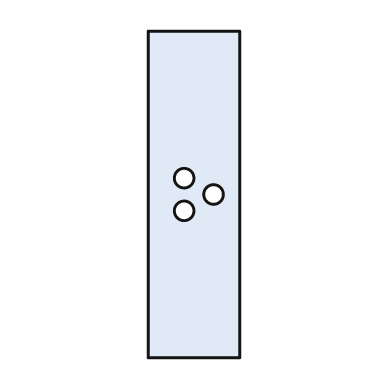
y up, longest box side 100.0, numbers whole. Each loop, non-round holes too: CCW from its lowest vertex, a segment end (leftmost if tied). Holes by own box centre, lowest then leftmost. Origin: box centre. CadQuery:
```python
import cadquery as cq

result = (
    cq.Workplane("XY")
    .moveTo(-14.0, -50.0)
    .lineTo(14.0, -50.0)
    .lineTo(14.0, 50.0)
    .lineTo(-14.0, 50.0)
    .close()
    .moveTo(-3.0, -5.0)
    .circle(3.0)
    .moveTo(6.0, 0.0)
    .circle(3.0)
    .moveTo(-3.0, 5.0)
    .circle(3.0)
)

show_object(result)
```